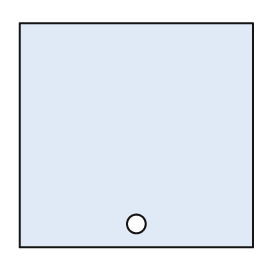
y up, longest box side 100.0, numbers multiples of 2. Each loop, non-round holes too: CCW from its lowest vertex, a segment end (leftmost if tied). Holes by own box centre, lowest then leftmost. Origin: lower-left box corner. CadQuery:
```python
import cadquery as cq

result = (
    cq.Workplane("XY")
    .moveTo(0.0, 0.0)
    .lineTo(100.0, 0.0)
    .lineTo(100.0, 96.0)
    .lineTo(0.0, 96.0)
    .close()
    .moveTo(50.0, 10.0)
    .circle(4.0)
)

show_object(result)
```